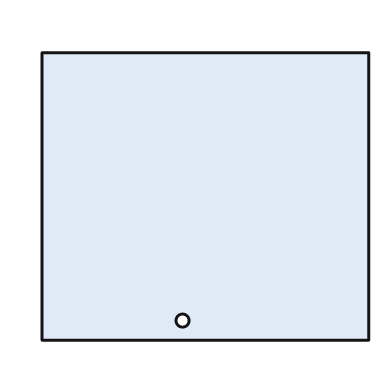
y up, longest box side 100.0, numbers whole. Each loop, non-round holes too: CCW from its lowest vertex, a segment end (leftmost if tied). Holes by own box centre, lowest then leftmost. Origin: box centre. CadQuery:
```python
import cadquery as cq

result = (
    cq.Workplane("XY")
    .moveTo(-50.0, -44.0)
    .lineTo(50.0, -44.0)
    .lineTo(50.0, 44.0)
    .lineTo(-50.0, 44.0)
    .close()
    .moveTo(-7.0, -38.0)
    .circle(2.0)
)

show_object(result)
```